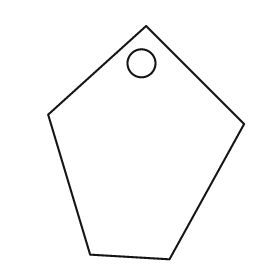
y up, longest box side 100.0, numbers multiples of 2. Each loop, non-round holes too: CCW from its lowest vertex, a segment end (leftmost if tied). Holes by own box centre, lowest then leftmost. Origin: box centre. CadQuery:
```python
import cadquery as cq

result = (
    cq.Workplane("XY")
    .moveTo(10.0, -50.0)
    .lineTo(42.0, 8.0)
    .lineTo(0.0, 50.0)
    .lineTo(-42.0, 12.0)
    .lineTo(-24.0, -48.0)
    .close()
    .moveTo(-2.0, 34.0)
    .circle(6.0)
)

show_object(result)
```